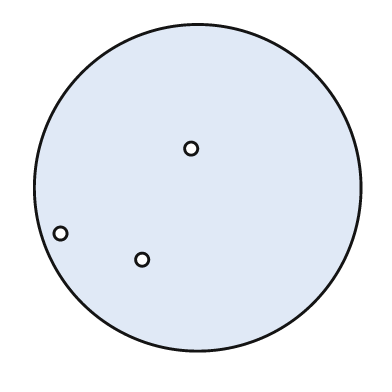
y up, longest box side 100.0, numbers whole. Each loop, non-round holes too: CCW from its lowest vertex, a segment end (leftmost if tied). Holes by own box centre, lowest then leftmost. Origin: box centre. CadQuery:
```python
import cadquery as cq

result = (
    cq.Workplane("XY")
    .moveTo(0.0, 0.0)
    .circle(50.0)
    .moveTo(-17.0, -22.0)
    .circle(2.0)
    .moveTo(-42.0, -14.0)
    .circle(2.0)
    .moveTo(-2.0, 12.0)
    .circle(2.0)
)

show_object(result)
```